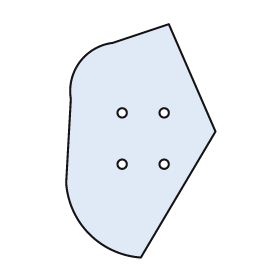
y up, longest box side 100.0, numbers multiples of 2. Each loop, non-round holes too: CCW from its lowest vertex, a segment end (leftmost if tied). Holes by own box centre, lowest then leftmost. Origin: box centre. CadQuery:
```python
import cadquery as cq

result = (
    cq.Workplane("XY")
    .moveTo(0.0, -50.0)
    .lineTo(32.0, 4.0)
    .lineTo(12.0, 50.0)
    .lineTo(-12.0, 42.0)
    .threePointArc((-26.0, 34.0), (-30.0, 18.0))
    .lineTo(-32.0, -18.0)
    .threePointArc((-22.0, -40.0), (0.0, -50.0))
    .close()
    .moveTo(-8.0, -10.0)
    .circle(2.0)
    .moveTo(10.0, -10.0)
    .circle(2.0)
    .moveTo(-8.0, 12.0)
    .circle(2.0)
    .moveTo(10.0, 12.0)
    .circle(2.0)
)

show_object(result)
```